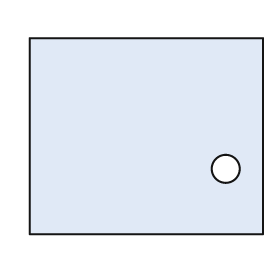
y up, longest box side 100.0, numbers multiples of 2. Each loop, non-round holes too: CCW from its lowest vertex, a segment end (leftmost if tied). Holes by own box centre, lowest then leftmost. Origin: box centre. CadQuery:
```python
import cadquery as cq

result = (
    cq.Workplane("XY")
    .moveTo(-50.0, -42.0)
    .lineTo(50.0, -42.0)
    .lineTo(50.0, 42.0)
    .lineTo(-50.0, 42.0)
    .close()
    .moveTo(34.0, -14.0)
    .circle(6.0)
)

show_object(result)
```